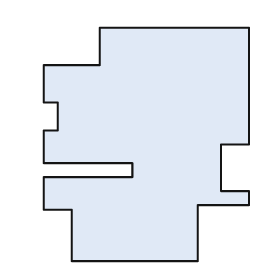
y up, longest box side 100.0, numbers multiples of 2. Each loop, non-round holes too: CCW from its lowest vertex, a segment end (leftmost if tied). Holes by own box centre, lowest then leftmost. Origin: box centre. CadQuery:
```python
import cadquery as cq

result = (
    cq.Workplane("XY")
    .moveTo(-32.0, -50.0)
    .lineTo(22.0, -50.0)
    .lineTo(22.0, -26.0)
    .lineTo(44.0, -26.0)
    .lineTo(44.0, -20.0)
    .lineTo(32.0, -20.0)
    .lineTo(32.0, 0.0)
    .lineTo(44.0, 0.0)
    .lineTo(44.0, 50.0)
    .lineTo(-20.0, 50.0)
    .lineTo(-20.0, 34.0)
    .lineTo(-44.0, 34.0)
    .lineTo(-44.0, 18.0)
    .lineTo(-38.0, 18.0)
    .lineTo(-38.0, 6.0)
    .lineTo(-44.0, 6.0)
    .lineTo(-44.0, -8.0)
    .lineTo(-6.0, -8.0)
    .lineTo(-6.0, -14.0)
    .lineTo(-44.0, -14.0)
    .lineTo(-44.0, -28.0)
    .lineTo(-32.0, -28.0)
    .close()
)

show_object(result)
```